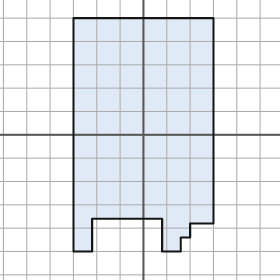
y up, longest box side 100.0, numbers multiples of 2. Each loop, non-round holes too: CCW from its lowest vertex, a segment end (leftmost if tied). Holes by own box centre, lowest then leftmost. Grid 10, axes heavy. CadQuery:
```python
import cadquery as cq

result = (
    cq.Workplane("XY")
    .moveTo(-30.0, -50.0)
    .lineTo(-22.0, -50.0)
    .lineTo(-22.0, -36.0)
    .lineTo(8.0, -36.0)
    .lineTo(8.0, -50.0)
    .lineTo(16.0, -50.0)
    .lineTo(16.0, -44.0)
    .lineTo(20.0, -44.0)
    .lineTo(20.0, -38.0)
    .lineTo(30.0, -38.0)
    .lineTo(30.0, 50.0)
    .lineTo(-30.0, 50.0)
    .close()
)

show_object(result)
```